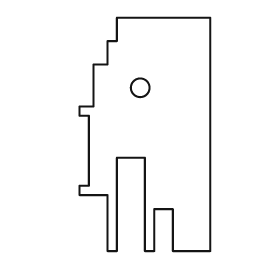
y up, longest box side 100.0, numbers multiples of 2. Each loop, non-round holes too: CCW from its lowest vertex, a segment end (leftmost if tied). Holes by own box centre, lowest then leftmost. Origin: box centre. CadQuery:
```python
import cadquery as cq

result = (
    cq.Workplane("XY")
    .moveTo(-16.0, -50.0)
    .lineTo(-12.0, -50.0)
    .lineTo(-12.0, -10.0)
    .lineTo(0.0, -10.0)
    .lineTo(0.0, -50.0)
    .lineTo(4.0, -50.0)
    .lineTo(4.0, -32.0)
    .lineTo(12.0, -32.0)
    .lineTo(12.0, -50.0)
    .lineTo(28.0, -50.0)
    .lineTo(28.0, 50.0)
    .lineTo(-12.0, 50.0)
    .lineTo(-12.0, 40.0)
    .lineTo(-16.0, 40.0)
    .lineTo(-16.0, 30.0)
    .lineTo(-22.0, 30.0)
    .lineTo(-22.0, 12.0)
    .lineTo(-28.0, 12.0)
    .lineTo(-28.0, 8.0)
    .lineTo(-24.0, 8.0)
    .lineTo(-24.0, -22.0)
    .lineTo(-28.0, -22.0)
    .lineTo(-28.0, -26.0)
    .lineTo(-16.0, -26.0)
    .close()
    .moveTo(-2.0, 20.0)
    .circle(4.0)
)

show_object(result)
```